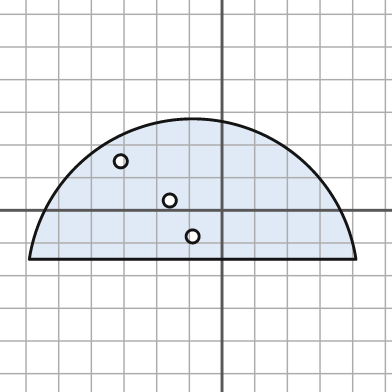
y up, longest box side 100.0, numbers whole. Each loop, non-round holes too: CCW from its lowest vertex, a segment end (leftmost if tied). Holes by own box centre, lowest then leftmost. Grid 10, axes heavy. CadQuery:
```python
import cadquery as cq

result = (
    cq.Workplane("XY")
    .moveTo(-59.0, -15.0)
    .lineTo(41.0, -15.0)
    .threePointArc((-9.0, 28.0), (-59.0, -15.0))
    .close()
    .moveTo(-9.0, -8.0)
    .circle(2.0)
    .moveTo(-16.0, 3.0)
    .circle(2.0)
    .moveTo(-31.0, 15.0)
    .circle(2.0)
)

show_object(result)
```